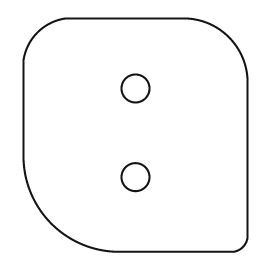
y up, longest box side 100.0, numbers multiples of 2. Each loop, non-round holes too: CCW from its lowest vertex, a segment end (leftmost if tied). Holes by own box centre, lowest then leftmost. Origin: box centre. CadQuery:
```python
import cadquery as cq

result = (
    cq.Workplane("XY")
    .moveTo(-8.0, -50.0)
    .lineTo(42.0, -50.0)
    .threePointArc((46.0, -48.0), (48.0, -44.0))
    .lineTo(48.0, 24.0)
    .threePointArc((40.0, 42.0), (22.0, 50.0))
    .lineTo(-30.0, 50.0)
    .threePointArc((-42.0, 44.0), (-48.0, 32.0))
    .lineTo(-48.0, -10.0)
    .threePointArc((-36.0, -38.0), (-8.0, -50.0))
    .close()
    .moveTo(0.0, -18.0)
    .circle(6.0)
    .moveTo(0.0, 20.0)
    .circle(6.0)
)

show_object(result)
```